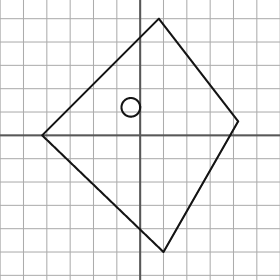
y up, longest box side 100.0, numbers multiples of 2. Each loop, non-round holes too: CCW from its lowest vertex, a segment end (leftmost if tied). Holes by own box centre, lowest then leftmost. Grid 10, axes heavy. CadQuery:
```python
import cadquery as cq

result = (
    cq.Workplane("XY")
    .moveTo(10.0, -50.0)
    .lineTo(42.0, 6.0)
    .lineTo(8.0, 50.0)
    .lineTo(-42.0, 0.0)
    .close()
    .moveTo(-4.0, 12.0)
    .circle(4.0)
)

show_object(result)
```